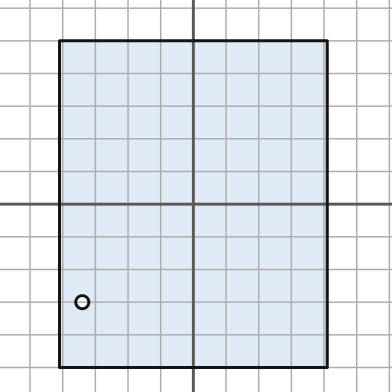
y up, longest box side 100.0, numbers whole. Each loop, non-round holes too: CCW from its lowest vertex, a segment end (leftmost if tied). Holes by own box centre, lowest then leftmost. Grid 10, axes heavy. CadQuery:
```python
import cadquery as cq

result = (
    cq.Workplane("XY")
    .moveTo(-41.0, -50.0)
    .lineTo(41.0, -50.0)
    .lineTo(41.0, 50.0)
    .lineTo(-41.0, 50.0)
    .close()
    .moveTo(-34.0, -30.0)
    .circle(2.0)
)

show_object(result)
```